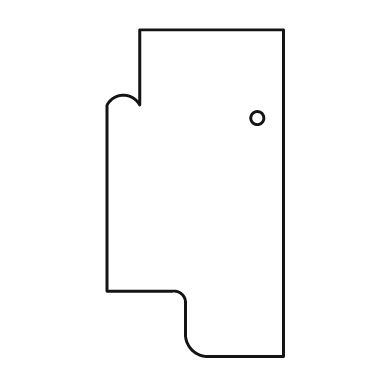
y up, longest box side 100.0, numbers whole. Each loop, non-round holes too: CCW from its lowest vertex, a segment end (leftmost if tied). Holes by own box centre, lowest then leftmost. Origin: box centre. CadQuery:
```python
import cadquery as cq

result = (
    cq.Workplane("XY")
    .moveTo(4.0, -50.0)
    .lineTo(27.0, -50.0)
    .lineTo(27.0, 50.0)
    .lineTo(-17.0, 50.0)
    .lineTo(-17.0, 27.0)
    .threePointArc((-22.0, 30.0), (-27.0, 27.0))
    .lineTo(-27.0, -30.0)
    .lineTo(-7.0, -30.0)
    .threePointArc((-4.0, -31.0), (-3.0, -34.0))
    .lineTo(-3.0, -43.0)
    .threePointArc((-1.0, -48.0), (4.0, -50.0))
    .close()
    .moveTo(19.0, 23.0)
    .circle(2.0)
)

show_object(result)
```